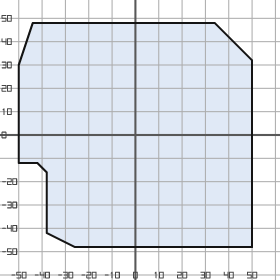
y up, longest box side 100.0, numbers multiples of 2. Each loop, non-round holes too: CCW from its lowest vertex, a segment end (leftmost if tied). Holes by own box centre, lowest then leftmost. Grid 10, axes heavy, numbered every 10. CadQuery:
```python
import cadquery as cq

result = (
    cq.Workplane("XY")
    .moveTo(-26.0, -48.0)
    .lineTo(50.0, -48.0)
    .lineTo(50.0, 32.0)
    .lineTo(34.0, 48.0)
    .lineTo(-44.0, 48.0)
    .lineTo(-50.0, 30.0)
    .lineTo(-50.0, -12.0)
    .lineTo(-42.0, -12.0)
    .lineTo(-38.0, -16.0)
    .lineTo(-38.0, -42.0)
    .close()
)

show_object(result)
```